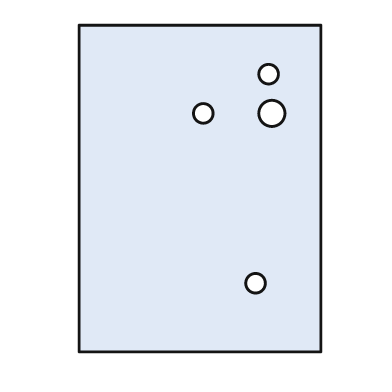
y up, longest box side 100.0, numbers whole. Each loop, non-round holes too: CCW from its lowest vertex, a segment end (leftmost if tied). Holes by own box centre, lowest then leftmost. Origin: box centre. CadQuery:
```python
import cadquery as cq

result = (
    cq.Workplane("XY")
    .moveTo(-37.0, -50.0)
    .lineTo(37.0, -50.0)
    .lineTo(37.0, 50.0)
    .lineTo(-37.0, 50.0)
    .close()
    .moveTo(17.0, -29.0)
    .circle(3.0)
    .moveTo(1.0, 23.0)
    .circle(3.0)
    .moveTo(22.0, 23.0)
    .circle(4.0)
    .moveTo(21.0, 35.0)
    .circle(3.0)
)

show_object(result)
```